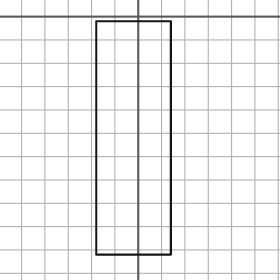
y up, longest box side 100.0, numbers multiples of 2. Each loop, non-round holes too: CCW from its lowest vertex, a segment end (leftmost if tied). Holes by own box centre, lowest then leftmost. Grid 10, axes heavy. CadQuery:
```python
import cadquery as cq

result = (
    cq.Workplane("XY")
    .moveTo(-18.0, -102.0)
    .lineTo(14.0, -102.0)
    .lineTo(14.0, -2.0)
    .lineTo(-18.0, -2.0)
    .close()
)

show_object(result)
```